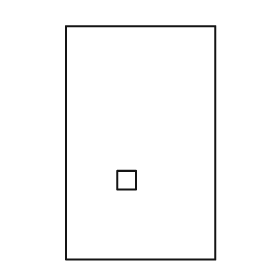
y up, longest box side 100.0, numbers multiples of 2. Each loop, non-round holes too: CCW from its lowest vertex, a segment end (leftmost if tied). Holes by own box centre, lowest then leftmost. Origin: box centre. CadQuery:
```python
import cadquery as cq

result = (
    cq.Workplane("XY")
    .moveTo(-32.0, -50.0)
    .lineTo(32.0, -50.0)
    .lineTo(32.0, 50.0)
    .lineTo(-32.0, 50.0)
    .close()
    .moveTo(-10.0, -20.0)
    .lineTo(-2.0, -20.0)
    .lineTo(-2.0, -12.0)
    .lineTo(-10.0, -12.0)
    .close()
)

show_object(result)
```